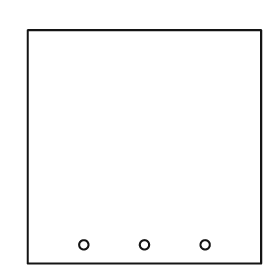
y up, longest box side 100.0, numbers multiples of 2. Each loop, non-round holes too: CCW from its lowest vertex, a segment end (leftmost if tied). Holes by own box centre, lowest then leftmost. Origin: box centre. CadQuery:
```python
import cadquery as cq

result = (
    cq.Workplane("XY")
    .moveTo(-50.0, -50.0)
    .lineTo(50.0, -50.0)
    .lineTo(50.0, 50.0)
    .lineTo(-50.0, 50.0)
    .close()
    .moveTo(-26.0, -42.0)
    .circle(2.0)
    .moveTo(0.0, -42.0)
    .circle(2.0)
    .moveTo(26.0, -42.0)
    .circle(2.0)
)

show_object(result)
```